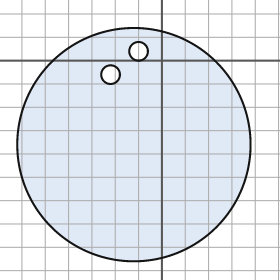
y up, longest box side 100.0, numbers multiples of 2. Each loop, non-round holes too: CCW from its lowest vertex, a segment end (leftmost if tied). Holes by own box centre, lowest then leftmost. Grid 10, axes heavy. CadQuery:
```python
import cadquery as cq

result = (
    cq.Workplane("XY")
    .moveTo(-12.0, -36.0)
    .circle(50.0)
    .moveTo(-22.0, -6.0)
    .circle(4.0)
    .moveTo(-10.0, 4.0)
    .circle(4.0)
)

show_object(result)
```